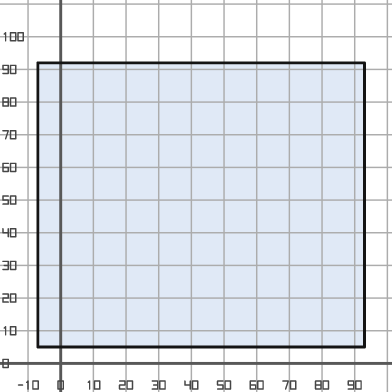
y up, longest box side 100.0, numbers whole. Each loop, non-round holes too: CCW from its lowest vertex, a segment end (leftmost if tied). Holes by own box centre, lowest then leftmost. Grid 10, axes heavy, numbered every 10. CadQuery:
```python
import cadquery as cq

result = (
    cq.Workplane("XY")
    .moveTo(-7.0, 5.0)
    .lineTo(93.0, 5.0)
    .lineTo(93.0, 92.0)
    .lineTo(-7.0, 92.0)
    .close()
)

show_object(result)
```